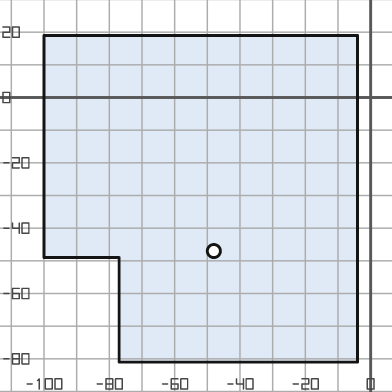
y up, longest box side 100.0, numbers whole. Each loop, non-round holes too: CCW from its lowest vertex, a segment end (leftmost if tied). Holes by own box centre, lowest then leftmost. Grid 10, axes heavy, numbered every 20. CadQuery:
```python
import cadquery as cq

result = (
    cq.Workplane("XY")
    .moveTo(-77.0, -81.0)
    .lineTo(-4.0, -81.0)
    .lineTo(-4.0, 19.0)
    .lineTo(-100.0, 19.0)
    .lineTo(-100.0, -49.0)
    .lineTo(-77.0, -49.0)
    .close()
    .moveTo(-48.0, -47.0)
    .circle(2.0)
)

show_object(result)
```